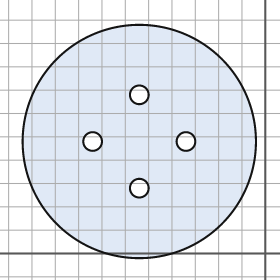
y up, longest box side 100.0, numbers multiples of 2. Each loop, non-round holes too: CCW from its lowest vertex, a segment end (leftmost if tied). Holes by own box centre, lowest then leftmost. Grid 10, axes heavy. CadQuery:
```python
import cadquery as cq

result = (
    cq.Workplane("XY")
    .moveTo(-54.0, 48.0)
    .circle(50.0)
    .moveTo(-54.0, 28.0)
    .circle(4.0)
    .moveTo(-74.0, 48.0)
    .circle(4.0)
    .moveTo(-34.0, 48.0)
    .circle(4.0)
    .moveTo(-54.0, 68.0)
    .circle(4.0)
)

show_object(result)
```